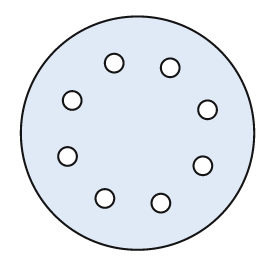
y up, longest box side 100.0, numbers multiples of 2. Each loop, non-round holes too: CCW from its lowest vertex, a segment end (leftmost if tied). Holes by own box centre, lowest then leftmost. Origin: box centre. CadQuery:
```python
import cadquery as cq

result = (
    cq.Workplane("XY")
    .moveTo(0.0, 0.0)
    .circle(50.0)
    .moveTo(10.0, -30.0)
    .circle(4.0)
    .moveTo(-14.0, -28.0)
    .circle(4.0)
    .moveTo(28.0, -14.0)
    .circle(4.0)
    .moveTo(-30.0, -10.0)
    .circle(4.0)
    .moveTo(30.0, 10.0)
    .circle(4.0)
    .moveTo(-28.0, 14.0)
    .circle(4.0)
    .moveTo(14.0, 28.0)
    .circle(4.0)
    .moveTo(-10.0, 30.0)
    .circle(4.0)
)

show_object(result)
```